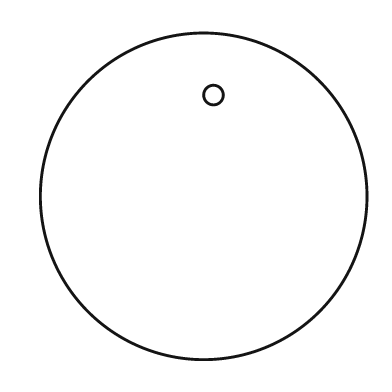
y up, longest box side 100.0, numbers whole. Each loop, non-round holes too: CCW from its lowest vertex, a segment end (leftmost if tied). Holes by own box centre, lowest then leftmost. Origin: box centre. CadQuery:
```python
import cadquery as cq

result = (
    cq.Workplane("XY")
    .moveTo(0.0, 0.0)
    .circle(50.0)
    .moveTo(3.0, 31.0)
    .circle(3.0)
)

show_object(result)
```